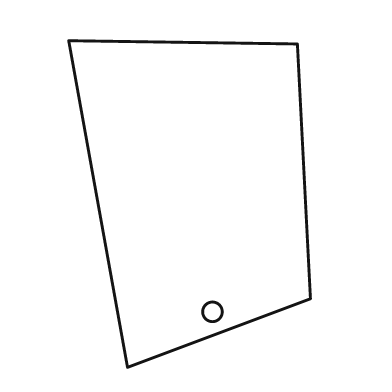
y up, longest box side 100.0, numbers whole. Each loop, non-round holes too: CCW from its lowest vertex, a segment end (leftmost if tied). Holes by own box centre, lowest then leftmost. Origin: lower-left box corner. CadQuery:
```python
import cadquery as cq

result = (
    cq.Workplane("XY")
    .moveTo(18.0, 0.0)
    .lineTo(74.0, 21.0)
    .lineTo(70.0, 99.0)
    .lineTo(0.0, 100.0)
    .close()
    .moveTo(44.0, 17.0)
    .circle(3.0)
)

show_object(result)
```